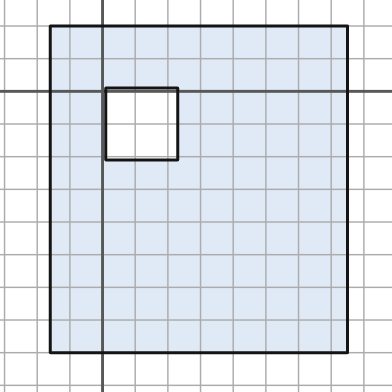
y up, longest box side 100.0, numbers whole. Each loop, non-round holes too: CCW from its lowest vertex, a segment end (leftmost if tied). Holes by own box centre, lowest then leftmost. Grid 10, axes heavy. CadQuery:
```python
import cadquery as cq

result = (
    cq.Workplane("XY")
    .moveTo(-16.0, -80.0)
    .lineTo(75.0, -80.0)
    .lineTo(75.0, 20.0)
    .lineTo(-16.0, 20.0)
    .close()
    .moveTo(1.0, -21.0)
    .lineTo(23.0, -21.0)
    .lineTo(23.0, 1.0)
    .lineTo(1.0, 1.0)
    .close()
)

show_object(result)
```